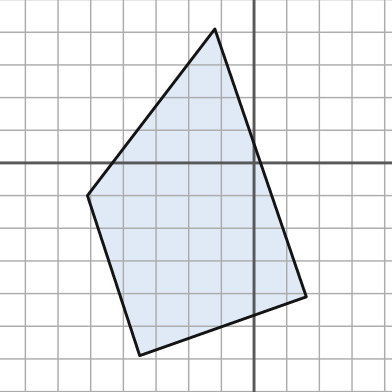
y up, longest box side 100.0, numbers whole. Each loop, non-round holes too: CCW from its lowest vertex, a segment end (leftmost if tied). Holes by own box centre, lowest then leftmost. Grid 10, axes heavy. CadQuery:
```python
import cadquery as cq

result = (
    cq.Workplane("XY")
    .moveTo(-35.0, -59.0)
    .lineTo(16.0, -41.0)
    .lineTo(-12.0, 41.0)
    .lineTo(-51.0, -10.0)
    .close()
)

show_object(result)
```